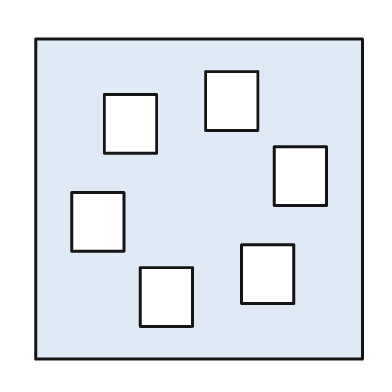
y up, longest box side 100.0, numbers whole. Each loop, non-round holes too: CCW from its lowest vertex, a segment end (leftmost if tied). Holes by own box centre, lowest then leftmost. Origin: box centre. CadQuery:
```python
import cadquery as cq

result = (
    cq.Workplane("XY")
    .moveTo(-50.0, -49.0)
    .lineTo(50.0, -49.0)
    .lineTo(50.0, 49.0)
    .lineTo(-50.0, 49.0)
    .close()
    .moveTo(-18.0, -39.0)
    .lineTo(-2.0, -39.0)
    .lineTo(-2.0, -21.0)
    .lineTo(-18.0, -21.0)
    .close()
    .moveTo(13.0, -32.0)
    .lineTo(29.0, -32.0)
    .lineTo(29.0, -14.0)
    .lineTo(13.0, -14.0)
    .close()
    .moveTo(-39.0, -16.0)
    .lineTo(-23.0, -16.0)
    .lineTo(-23.0, 2.0)
    .lineTo(-39.0, 2.0)
    .close()
    .moveTo(23.0, -2.0)
    .lineTo(39.0, -2.0)
    .lineTo(39.0, 16.0)
    .lineTo(23.0, 16.0)
    .close()
    .moveTo(-29.0, 14.0)
    .lineTo(-13.0, 14.0)
    .lineTo(-13.0, 32.0)
    .lineTo(-29.0, 32.0)
    .close()
    .moveTo(2.0, 21.0)
    .lineTo(18.0, 21.0)
    .lineTo(18.0, 39.0)
    .lineTo(2.0, 39.0)
    .close()
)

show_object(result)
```